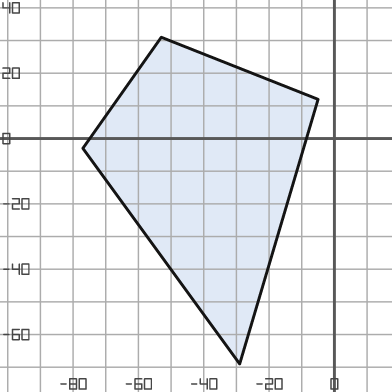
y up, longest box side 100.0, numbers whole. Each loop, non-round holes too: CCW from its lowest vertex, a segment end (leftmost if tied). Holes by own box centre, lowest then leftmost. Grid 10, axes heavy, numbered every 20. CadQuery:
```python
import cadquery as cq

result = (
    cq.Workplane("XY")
    .moveTo(-29.0, -69.0)
    .lineTo(-5.0, 12.0)
    .lineTo(-53.0, 31.0)
    .lineTo(-77.0, -3.0)
    .close()
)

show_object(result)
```